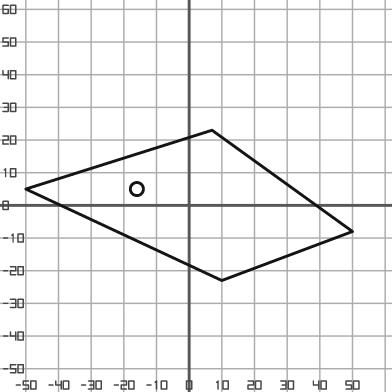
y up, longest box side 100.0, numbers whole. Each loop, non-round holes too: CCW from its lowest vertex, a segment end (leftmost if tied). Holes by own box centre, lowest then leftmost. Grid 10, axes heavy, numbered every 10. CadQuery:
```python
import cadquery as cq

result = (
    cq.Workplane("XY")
    .moveTo(10.0, -23.0)
    .lineTo(50.0, -8.0)
    .lineTo(7.0, 23.0)
    .lineTo(-50.0, 5.0)
    .close()
    .moveTo(-16.0, 5.0)
    .circle(2.0)
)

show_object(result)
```